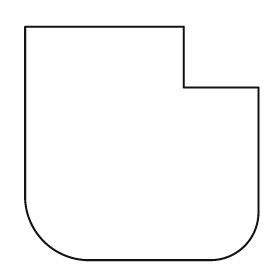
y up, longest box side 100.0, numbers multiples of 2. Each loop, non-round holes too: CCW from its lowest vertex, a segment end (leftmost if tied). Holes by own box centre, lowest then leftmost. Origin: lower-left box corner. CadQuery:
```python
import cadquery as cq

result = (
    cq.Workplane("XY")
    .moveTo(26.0, 0.0)
    .lineTo(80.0, 0.0)
    .threePointArc((94.0, 6.0), (100.0, 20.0))
    .lineTo(100.0, 74.0)
    .lineTo(68.0, 74.0)
    .lineTo(68.0, 100.0)
    .lineTo(0.0, 100.0)
    .lineTo(0.0, 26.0)
    .threePointArc((8.0, 8.0), (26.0, 0.0))
    .close()
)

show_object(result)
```